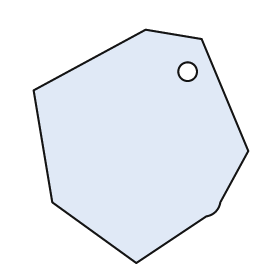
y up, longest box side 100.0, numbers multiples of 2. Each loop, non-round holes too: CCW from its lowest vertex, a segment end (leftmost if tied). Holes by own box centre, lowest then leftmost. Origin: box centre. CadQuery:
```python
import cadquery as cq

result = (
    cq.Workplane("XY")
    .moveTo(-2.0, -50.0)
    .lineTo(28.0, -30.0)
    .threePointArc((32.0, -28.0), (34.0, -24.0))
    .lineTo(46.0, -2.0)
    .lineTo(26.0, 46.0)
    .lineTo(2.0, 50.0)
    .lineTo(-46.0, 24.0)
    .lineTo(-38.0, -24.0)
    .close()
    .moveTo(20.0, 32.0)
    .circle(4.0)
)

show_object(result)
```